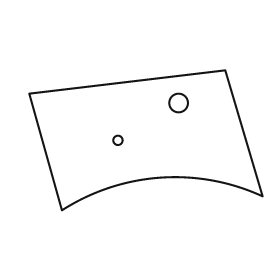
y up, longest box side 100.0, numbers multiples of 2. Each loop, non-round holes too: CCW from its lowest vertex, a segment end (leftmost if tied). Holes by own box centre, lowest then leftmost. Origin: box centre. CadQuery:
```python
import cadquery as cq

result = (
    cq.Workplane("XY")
    .moveTo(-36.0, -30.0)
    .threePointArc((6.0, -16.0), (50.0, -24.0))
    .lineTo(34.0, 30.0)
    .lineTo(-50.0, 20.0)
    .close()
    .moveTo(-12.0, 0.0)
    .circle(2.0)
    .moveTo(14.0, 16.0)
    .circle(4.0)
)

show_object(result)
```